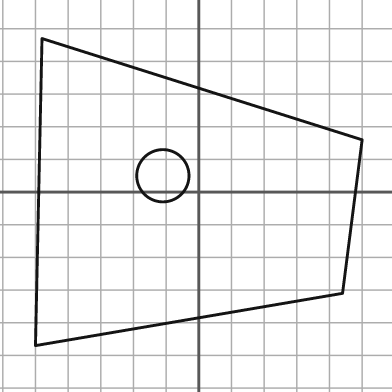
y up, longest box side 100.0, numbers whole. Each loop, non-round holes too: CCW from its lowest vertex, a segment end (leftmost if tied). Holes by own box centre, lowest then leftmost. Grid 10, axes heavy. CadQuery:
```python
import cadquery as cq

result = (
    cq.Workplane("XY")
    .moveTo(-50.0, -47.0)
    .lineTo(44.0, -31.0)
    .lineTo(50.0, 16.0)
    .lineTo(-48.0, 47.0)
    .close()
    .moveTo(-11.0, 5.0)
    .circle(8.0)
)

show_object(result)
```